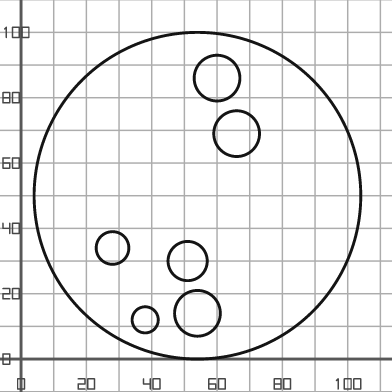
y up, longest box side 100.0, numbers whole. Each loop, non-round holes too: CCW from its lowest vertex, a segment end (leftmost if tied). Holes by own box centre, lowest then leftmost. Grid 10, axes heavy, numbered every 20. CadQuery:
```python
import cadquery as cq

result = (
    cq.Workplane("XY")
    .moveTo(54.0, 50.0)
    .circle(50.0)
    .moveTo(38.0, 12.0)
    .circle(4.0)
    .moveTo(54.0, 14.0)
    .circle(7.0)
    .moveTo(51.0, 30.0)
    .circle(6.0)
    .moveTo(28.0, 34.0)
    .circle(5.0)
    .moveTo(66.0, 69.0)
    .circle(7.0)
    .moveTo(60.0, 86.0)
    .circle(7.0)
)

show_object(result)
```